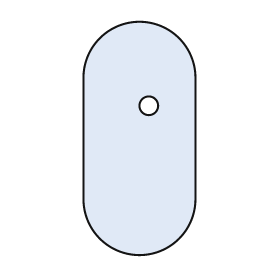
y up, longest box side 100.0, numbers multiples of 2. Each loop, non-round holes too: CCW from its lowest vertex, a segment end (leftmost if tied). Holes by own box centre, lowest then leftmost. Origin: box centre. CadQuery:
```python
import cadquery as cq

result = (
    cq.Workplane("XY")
    .moveTo(-24.0, -26.0)
    .threePointArc((0.0, -50.0), (24.0, -26.0))
    .lineTo(24.0, 26.0)
    .threePointArc((0.0, 50.0), (-24.0, 26.0))
    .close()
    .moveTo(4.0, 14.0)
    .circle(4.0)
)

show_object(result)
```